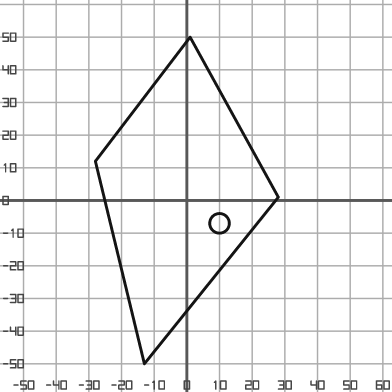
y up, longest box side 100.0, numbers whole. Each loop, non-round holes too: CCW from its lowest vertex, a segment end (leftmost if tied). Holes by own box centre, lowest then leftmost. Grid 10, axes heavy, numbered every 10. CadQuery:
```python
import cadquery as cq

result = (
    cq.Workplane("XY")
    .moveTo(-13.0, -50.0)
    .lineTo(28.0, 1.0)
    .lineTo(1.0, 50.0)
    .lineTo(-28.0, 12.0)
    .close()
    .moveTo(10.0, -7.0)
    .circle(3.0)
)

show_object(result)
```